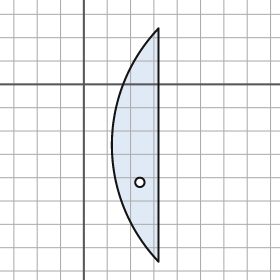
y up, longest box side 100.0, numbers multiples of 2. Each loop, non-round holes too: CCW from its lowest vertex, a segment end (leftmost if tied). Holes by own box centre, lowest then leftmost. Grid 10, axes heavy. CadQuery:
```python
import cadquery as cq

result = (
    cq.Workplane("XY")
    .moveTo(32.0, -76.0)
    .lineTo(32.0, 24.0)
    .threePointArc((12.0, -26.0), (32.0, -76.0))
    .close()
    .moveTo(24.0, -42.0)
    .circle(2.0)
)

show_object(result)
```